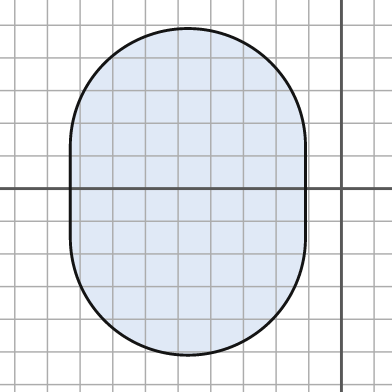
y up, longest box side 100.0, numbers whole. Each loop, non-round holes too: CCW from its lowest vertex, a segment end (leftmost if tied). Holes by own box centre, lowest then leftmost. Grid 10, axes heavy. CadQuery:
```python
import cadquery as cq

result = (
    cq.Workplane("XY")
    .moveTo(-83.0, -15.0)
    .threePointArc((-47.0, -51.0), (-11.0, -15.0))
    .lineTo(-11.0, 13.0)
    .threePointArc((-47.0, 49.0), (-83.0, 13.0))
    .close()
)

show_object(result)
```